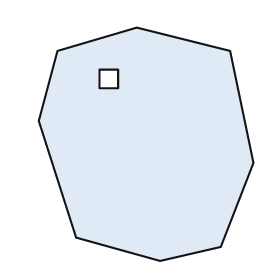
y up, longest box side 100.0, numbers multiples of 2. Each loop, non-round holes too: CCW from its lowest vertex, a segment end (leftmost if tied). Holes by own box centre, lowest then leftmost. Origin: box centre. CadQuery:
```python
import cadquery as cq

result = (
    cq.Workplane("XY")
    .moveTo(6.0, -50.0)
    .lineTo(32.0, -44.0)
    .lineTo(46.0, -8.0)
    .lineTo(36.0, 40.0)
    .lineTo(-4.0, 50.0)
    .lineTo(-38.0, 40.0)
    .lineTo(-46.0, 10.0)
    .lineTo(-30.0, -40.0)
    .close()
    .moveTo(-20.0, 24.0)
    .lineTo(-12.0, 24.0)
    .lineTo(-12.0, 32.0)
    .lineTo(-20.0, 32.0)
    .close()
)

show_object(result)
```